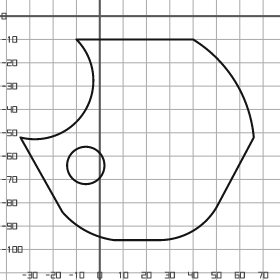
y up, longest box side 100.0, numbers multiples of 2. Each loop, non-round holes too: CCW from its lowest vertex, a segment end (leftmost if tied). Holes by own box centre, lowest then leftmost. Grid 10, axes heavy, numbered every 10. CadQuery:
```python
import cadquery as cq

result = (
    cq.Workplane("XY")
    .moveTo(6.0, -96.0)
    .lineTo(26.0, -96.0)
    .threePointArc((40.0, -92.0), (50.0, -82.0))
    .lineTo(66.0, -52.0)
    .threePointArc((58.0, -28.0), (40.0, -10.0))
    .lineTo(-10.0, -10.0)
    .threePointArc((-6.0, -40.0), (-34.0, -52.0))
    .lineTo(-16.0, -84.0)
    .threePointArc((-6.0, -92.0), (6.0, -96.0))
    .close()
    .moveTo(-6.0, -64.0)
    .circle(8.0)
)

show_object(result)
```